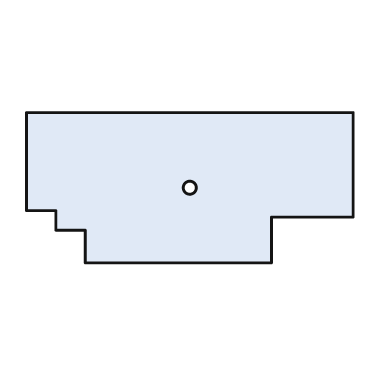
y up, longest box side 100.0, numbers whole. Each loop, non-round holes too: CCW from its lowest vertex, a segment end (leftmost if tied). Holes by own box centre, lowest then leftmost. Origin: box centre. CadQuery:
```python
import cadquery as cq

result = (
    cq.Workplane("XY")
    .moveTo(-32.0, -23.0)
    .lineTo(25.0, -23.0)
    .lineTo(25.0, -9.0)
    .lineTo(50.0, -9.0)
    .lineTo(50.0, 23.0)
    .lineTo(-50.0, 23.0)
    .lineTo(-50.0, -7.0)
    .lineTo(-41.0, -7.0)
    .lineTo(-41.0, -13.0)
    .lineTo(-32.0, -13.0)
    .close()
    .moveTo(0.0, 0.0)
    .circle(2.0)
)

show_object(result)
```